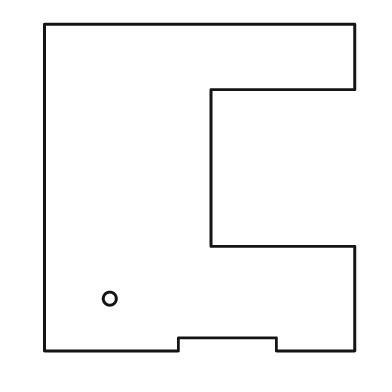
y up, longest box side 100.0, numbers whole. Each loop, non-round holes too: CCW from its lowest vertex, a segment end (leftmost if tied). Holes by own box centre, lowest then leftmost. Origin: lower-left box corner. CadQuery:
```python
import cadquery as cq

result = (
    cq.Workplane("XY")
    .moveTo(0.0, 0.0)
    .lineTo(41.0, 0.0)
    .lineTo(41.0, 4.0)
    .lineTo(71.0, 4.0)
    .lineTo(71.0, 0.0)
    .lineTo(95.0, 0.0)
    .lineTo(95.0, 32.0)
    .lineTo(51.0, 32.0)
    .lineTo(51.0, 80.0)
    .lineTo(95.0, 80.0)
    .lineTo(95.0, 100.0)
    .lineTo(0.0, 100.0)
    .close()
    .moveTo(20.0, 16.0)
    .circle(2.0)
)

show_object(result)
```